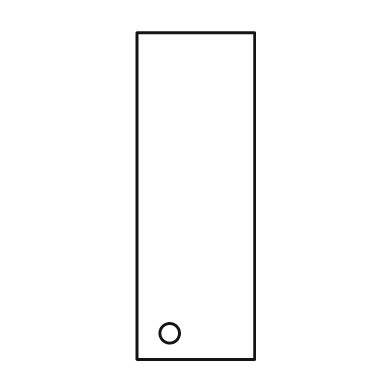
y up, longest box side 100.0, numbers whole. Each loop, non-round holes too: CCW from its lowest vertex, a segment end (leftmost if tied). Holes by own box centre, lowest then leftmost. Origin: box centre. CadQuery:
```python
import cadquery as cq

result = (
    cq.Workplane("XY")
    .moveTo(-18.0, -50.0)
    .lineTo(18.0, -50.0)
    .lineTo(18.0, 50.0)
    .lineTo(-18.0, 50.0)
    .close()
    .moveTo(-8.0, -42.0)
    .circle(3.0)
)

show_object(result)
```